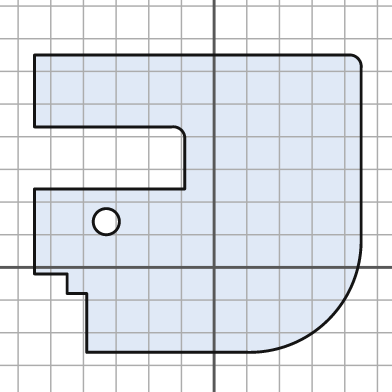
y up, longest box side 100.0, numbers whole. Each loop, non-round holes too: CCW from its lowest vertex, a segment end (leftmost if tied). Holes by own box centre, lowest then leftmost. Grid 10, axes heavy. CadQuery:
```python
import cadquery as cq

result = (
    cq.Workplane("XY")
    .moveTo(-39.0, -26.0)
    .lineTo(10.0, -26.0)
    .threePointArc((35.0, -16.0), (45.0, 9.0))
    .lineTo(45.0, 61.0)
    .threePointArc((44.0, 64.0), (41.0, 65.0))
    .lineTo(-55.0, 65.0)
    .lineTo(-55.0, 43.0)
    .lineTo(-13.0, 43.0)
    .threePointArc((-10.0, 42.0), (-9.0, 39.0))
    .lineTo(-9.0, 24.0)
    .lineTo(-55.0, 24.0)
    .lineTo(-55.0, -2.0)
    .lineTo(-45.0, -2.0)
    .lineTo(-45.0, -8.0)
    .lineTo(-39.0, -8.0)
    .close()
    .moveTo(-33.0, 14.0)
    .circle(4.0)
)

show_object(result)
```